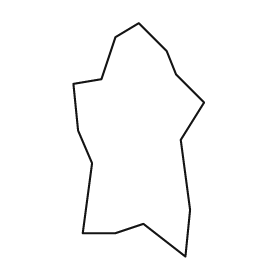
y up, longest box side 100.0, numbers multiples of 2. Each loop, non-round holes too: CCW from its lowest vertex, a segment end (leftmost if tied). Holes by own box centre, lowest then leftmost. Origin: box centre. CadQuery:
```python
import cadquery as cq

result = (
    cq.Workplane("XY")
    .moveTo(20.0, -50.0)
    .lineTo(22.0, -30.0)
    .lineTo(18.0, 0.0)
    .lineTo(28.0, 16.0)
    .lineTo(16.0, 28.0)
    .lineTo(12.0, 38.0)
    .lineTo(0.0, 50.0)
    .lineTo(-10.0, 44.0)
    .lineTo(-16.0, 26.0)
    .lineTo(-28.0, 24.0)
    .lineTo(-26.0, 4.0)
    .lineTo(-20.0, -10.0)
    .lineTo(-24.0, -40.0)
    .lineTo(-10.0, -40.0)
    .lineTo(2.0, -36.0)
    .close()
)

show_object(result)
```